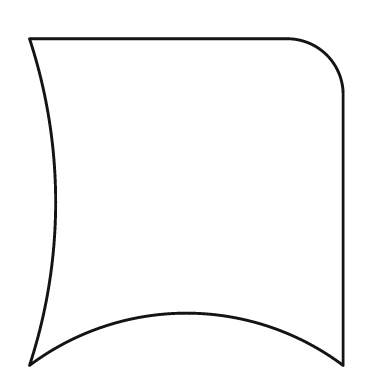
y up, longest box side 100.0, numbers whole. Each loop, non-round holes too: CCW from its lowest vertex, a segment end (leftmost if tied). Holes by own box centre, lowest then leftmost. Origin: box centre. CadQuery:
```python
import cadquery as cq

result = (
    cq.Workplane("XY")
    .moveTo(-48.0, -50.0)
    .threePointArc((0.0, -34.0), (48.0, -50.0))
    .lineTo(48.0, 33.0)
    .threePointArc((43.0, 45.0), (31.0, 50.0))
    .lineTo(-48.0, 50.0)
    .threePointArc((-40.0, 0.0), (-48.0, -50.0))
    .close()
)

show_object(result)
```